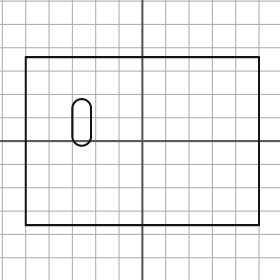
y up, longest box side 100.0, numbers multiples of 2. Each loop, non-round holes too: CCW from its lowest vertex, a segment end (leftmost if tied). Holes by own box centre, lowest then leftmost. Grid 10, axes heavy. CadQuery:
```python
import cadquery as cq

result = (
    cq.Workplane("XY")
    .moveTo(-50.0, -36.0)
    .lineTo(50.0, -36.0)
    .lineTo(50.0, 36.0)
    .lineTo(-50.0, 36.0)
    .close()
    .moveTo(-30.0, 2.0)
    .threePointArc((-26.0, -2.0), (-22.0, 2.0))
    .lineTo(-22.0, 14.0)
    .threePointArc((-26.0, 18.0), (-30.0, 14.0))
    .close()
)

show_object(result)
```